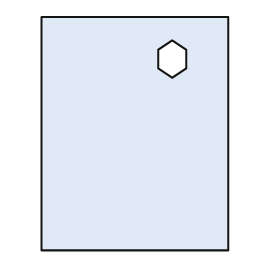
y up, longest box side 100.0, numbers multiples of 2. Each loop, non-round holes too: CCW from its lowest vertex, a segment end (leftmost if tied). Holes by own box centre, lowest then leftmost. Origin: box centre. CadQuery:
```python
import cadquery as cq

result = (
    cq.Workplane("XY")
    .moveTo(-40.0, -50.0)
    .lineTo(40.0, -50.0)
    .lineTo(40.0, 50.0)
    .lineTo(-40.0, 50.0)
    .close()
    .moveTo(16.0, 24.0)
    .lineTo(22.0, 28.0)
    .lineTo(22.0, 36.0)
    .lineTo(16.0, 40.0)
    .lineTo(10.0, 36.0)
    .lineTo(10.0, 28.0)
    .close()
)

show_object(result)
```